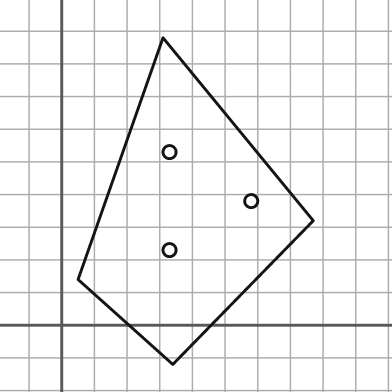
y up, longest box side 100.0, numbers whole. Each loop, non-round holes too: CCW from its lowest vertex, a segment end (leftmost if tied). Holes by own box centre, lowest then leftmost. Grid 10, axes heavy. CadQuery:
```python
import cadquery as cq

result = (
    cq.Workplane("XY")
    .moveTo(34.0, -12.0)
    .lineTo(77.0, 32.0)
    .lineTo(31.0, 88.0)
    .lineTo(5.0, 14.0)
    .close()
    .moveTo(33.0, 23.0)
    .circle(2.0)
    .moveTo(58.0, 38.0)
    .circle(2.0)
    .moveTo(33.0, 53.0)
    .circle(2.0)
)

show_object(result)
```